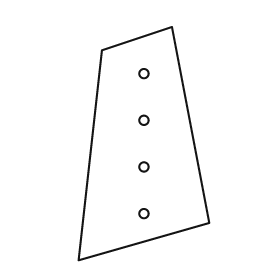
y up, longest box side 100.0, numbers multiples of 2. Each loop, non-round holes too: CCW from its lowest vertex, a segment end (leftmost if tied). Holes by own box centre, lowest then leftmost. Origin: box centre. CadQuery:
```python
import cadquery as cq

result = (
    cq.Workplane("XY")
    .moveTo(-28.0, -50.0)
    .lineTo(28.0, -34.0)
    .lineTo(12.0, 50.0)
    .lineTo(-18.0, 40.0)
    .close()
    .moveTo(0.0, -30.0)
    .circle(2.0)
    .moveTo(0.0, -10.0)
    .circle(2.0)
    .moveTo(0.0, 10.0)
    .circle(2.0)
    .moveTo(0.0, 30.0)
    .circle(2.0)
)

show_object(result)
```